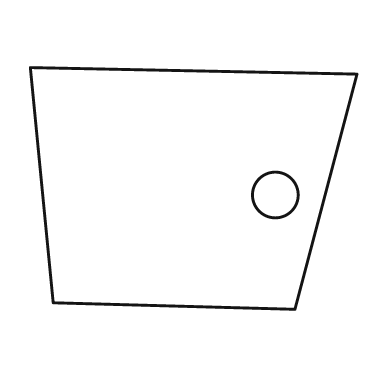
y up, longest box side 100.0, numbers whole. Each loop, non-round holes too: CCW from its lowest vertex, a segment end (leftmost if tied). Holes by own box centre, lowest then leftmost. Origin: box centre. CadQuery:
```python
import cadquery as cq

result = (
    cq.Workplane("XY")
    .moveTo(31.0, -37.0)
    .lineTo(50.0, 35.0)
    .lineTo(-50.0, 37.0)
    .lineTo(-43.0, -35.0)
    .close()
    .moveTo(25.0, -2.0)
    .circle(7.0)
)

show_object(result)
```